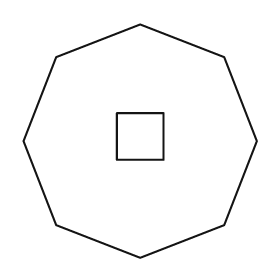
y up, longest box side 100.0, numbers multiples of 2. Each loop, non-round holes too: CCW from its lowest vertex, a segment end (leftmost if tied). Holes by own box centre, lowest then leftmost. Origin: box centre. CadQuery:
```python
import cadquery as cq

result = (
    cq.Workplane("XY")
    .moveTo(0.0, -50.0)
    .lineTo(36.0, -36.0)
    .lineTo(50.0, 0.0)
    .lineTo(36.0, 36.0)
    .lineTo(0.0, 50.0)
    .lineTo(-36.0, 36.0)
    .lineTo(-50.0, 0.0)
    .lineTo(-36.0, -36.0)
    .close()
    .moveTo(-10.0, -8.0)
    .lineTo(10.0, -8.0)
    .lineTo(10.0, 12.0)
    .lineTo(-10.0, 12.0)
    .close()
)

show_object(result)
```